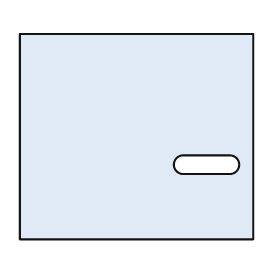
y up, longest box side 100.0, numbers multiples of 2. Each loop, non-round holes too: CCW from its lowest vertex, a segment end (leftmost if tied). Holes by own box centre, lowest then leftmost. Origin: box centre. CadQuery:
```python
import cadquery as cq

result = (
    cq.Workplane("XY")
    .moveTo(-50.0, -44.0)
    .lineTo(50.0, -44.0)
    .lineTo(50.0, 44.0)
    .lineTo(-50.0, 44.0)
    .close()
    .moveTo(20.0, -16.0)
    .lineTo(40.0, -16.0)
    .threePointArc((44.0, -12.0), (40.0, -8.0))
    .lineTo(20.0, -8.0)
    .threePointArc((16.0, -12.0), (20.0, -16.0))
    .close()
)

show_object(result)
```